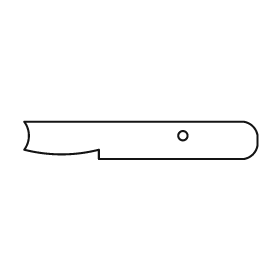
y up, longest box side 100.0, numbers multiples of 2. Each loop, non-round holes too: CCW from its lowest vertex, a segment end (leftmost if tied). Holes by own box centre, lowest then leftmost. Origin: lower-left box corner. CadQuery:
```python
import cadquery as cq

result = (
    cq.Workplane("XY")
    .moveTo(32.0, 0.0)
    .lineTo(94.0, 0.0)
    .threePointArc((98.0, 2.0), (100.0, 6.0))
    .lineTo(100.0, 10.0)
    .threePointArc((98.0, 14.0), (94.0, 16.0))
    .lineTo(0.0, 16.0)
    .threePointArc((2.0, 10.0), (0.0, 4.0))
    .threePointArc((16.0, 2.0), (32.0, 4.0))
    .close()
    .moveTo(68.0, 10.0)
    .circle(2.0)
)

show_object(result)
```